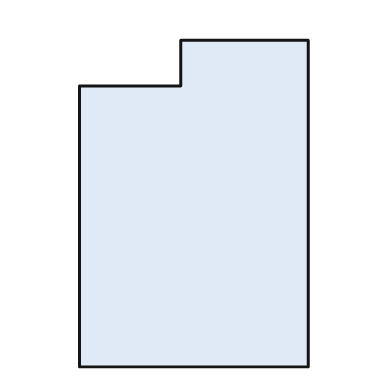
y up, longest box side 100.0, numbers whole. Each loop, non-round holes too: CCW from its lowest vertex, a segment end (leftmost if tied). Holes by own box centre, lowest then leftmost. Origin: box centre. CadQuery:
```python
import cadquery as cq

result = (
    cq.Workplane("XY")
    .moveTo(-35.0, -50.0)
    .lineTo(35.0, -50.0)
    .lineTo(35.0, 50.0)
    .lineTo(-4.0, 50.0)
    .lineTo(-4.0, 36.0)
    .lineTo(-35.0, 36.0)
    .close()
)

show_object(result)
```